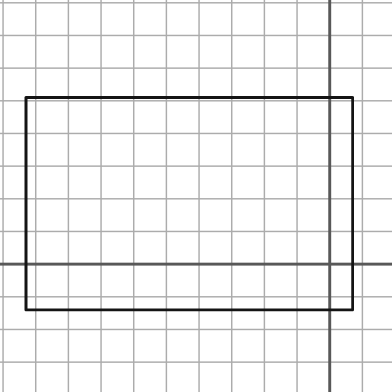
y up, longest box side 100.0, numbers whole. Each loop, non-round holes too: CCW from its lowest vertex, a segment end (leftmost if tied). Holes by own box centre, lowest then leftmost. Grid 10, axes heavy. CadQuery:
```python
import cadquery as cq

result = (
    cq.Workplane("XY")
    .moveTo(-93.0, -14.0)
    .lineTo(7.0, -14.0)
    .lineTo(7.0, 51.0)
    .lineTo(-93.0, 51.0)
    .close()
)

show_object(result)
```